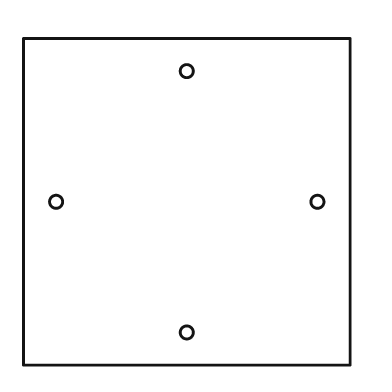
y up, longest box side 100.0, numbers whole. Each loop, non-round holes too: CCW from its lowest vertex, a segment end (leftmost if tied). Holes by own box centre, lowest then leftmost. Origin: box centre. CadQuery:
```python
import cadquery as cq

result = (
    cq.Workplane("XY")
    .moveTo(-50.0, -50.0)
    .lineTo(50.0, -50.0)
    .lineTo(50.0, 50.0)
    .lineTo(-50.0, 50.0)
    .close()
    .moveTo(0.0, -40.0)
    .circle(2.0)
    .moveTo(-40.0, 0.0)
    .circle(2.0)
    .moveTo(40.0, 0.0)
    .circle(2.0)
    .moveTo(0.0, 40.0)
    .circle(2.0)
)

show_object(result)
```